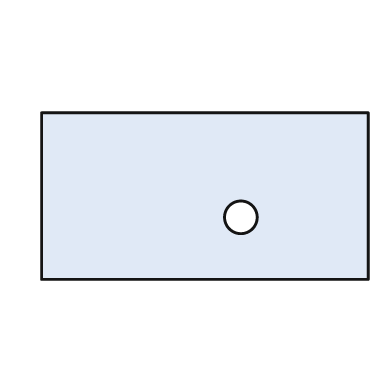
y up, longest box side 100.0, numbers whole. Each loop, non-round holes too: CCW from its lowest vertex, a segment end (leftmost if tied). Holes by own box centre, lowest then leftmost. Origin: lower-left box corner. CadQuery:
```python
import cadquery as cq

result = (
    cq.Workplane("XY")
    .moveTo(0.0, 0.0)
    .lineTo(100.0, 0.0)
    .lineTo(100.0, 51.0)
    .lineTo(0.0, 51.0)
    .close()
    .moveTo(61.0, 19.0)
    .circle(5.0)
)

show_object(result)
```